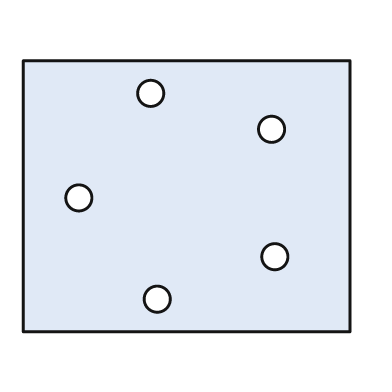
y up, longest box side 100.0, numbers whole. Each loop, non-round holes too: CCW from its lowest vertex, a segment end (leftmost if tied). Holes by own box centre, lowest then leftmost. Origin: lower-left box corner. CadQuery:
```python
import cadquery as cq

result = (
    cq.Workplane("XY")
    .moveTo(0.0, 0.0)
    .lineTo(100.0, 0.0)
    .lineTo(100.0, 83.0)
    .lineTo(0.0, 83.0)
    .close()
    .moveTo(41.0, 10.0)
    .circle(4.0)
    .moveTo(77.0, 23.0)
    .circle(4.0)
    .moveTo(17.0, 41.0)
    .circle(4.0)
    .moveTo(76.0, 62.0)
    .circle(4.0)
    .moveTo(39.0, 73.0)
    .circle(4.0)
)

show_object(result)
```